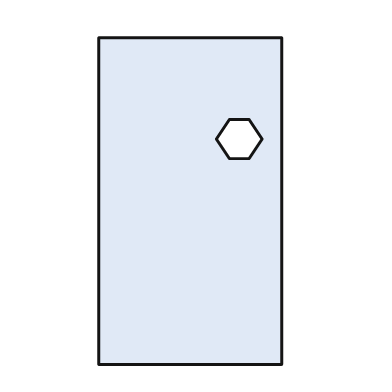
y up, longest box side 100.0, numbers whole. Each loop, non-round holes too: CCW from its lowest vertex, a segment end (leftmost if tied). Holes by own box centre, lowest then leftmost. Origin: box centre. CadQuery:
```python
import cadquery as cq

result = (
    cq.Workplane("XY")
    .moveTo(-28.0, -50.0)
    .lineTo(28.0, -50.0)
    .lineTo(28.0, 50.0)
    .lineTo(-28.0, 50.0)
    .close()
    .moveTo(12.0, 13.0)
    .lineTo(18.0, 13.0)
    .lineTo(22.0, 19.0)
    .lineTo(18.0, 25.0)
    .lineTo(12.0, 25.0)
    .lineTo(8.0, 19.0)
    .close()
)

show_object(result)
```